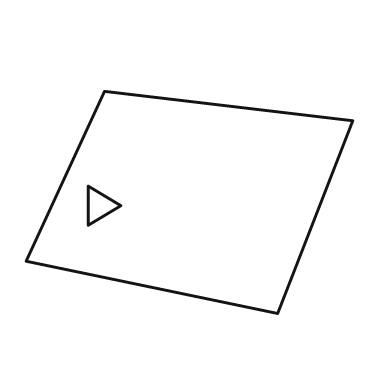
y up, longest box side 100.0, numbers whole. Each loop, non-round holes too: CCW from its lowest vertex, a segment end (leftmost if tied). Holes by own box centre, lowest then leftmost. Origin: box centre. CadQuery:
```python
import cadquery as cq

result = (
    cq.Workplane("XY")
    .moveTo(27.0, -34.0)
    .lineTo(50.0, 25.0)
    .lineTo(-26.0, 34.0)
    .lineTo(-50.0, -18.0)
    .close()
    .moveTo(-31.0, -7.0)
    .lineTo(-21.0, -1.0)
    .lineTo(-31.0, 5.0)
    .close()
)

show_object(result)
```